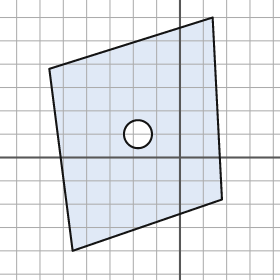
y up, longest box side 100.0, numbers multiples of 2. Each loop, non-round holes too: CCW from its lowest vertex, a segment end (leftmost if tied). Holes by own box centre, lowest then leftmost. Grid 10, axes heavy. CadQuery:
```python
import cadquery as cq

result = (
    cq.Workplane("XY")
    .moveTo(-46.0, -40.0)
    .lineTo(18.0, -18.0)
    .lineTo(14.0, 60.0)
    .lineTo(-56.0, 38.0)
    .close()
    .moveTo(-18.0, 10.0)
    .circle(6.0)
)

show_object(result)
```